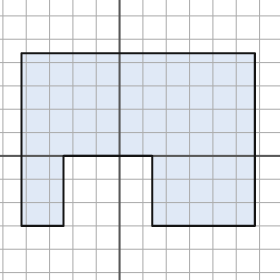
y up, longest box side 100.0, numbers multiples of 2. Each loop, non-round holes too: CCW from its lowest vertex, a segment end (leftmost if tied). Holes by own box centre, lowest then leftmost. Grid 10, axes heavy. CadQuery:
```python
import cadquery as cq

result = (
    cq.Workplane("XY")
    .moveTo(-42.0, -30.0)
    .lineTo(-24.0, -30.0)
    .lineTo(-24.0, 0.0)
    .lineTo(14.0, 0.0)
    .lineTo(14.0, -30.0)
    .lineTo(58.0, -30.0)
    .lineTo(58.0, 44.0)
    .lineTo(-42.0, 44.0)
    .close()
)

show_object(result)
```